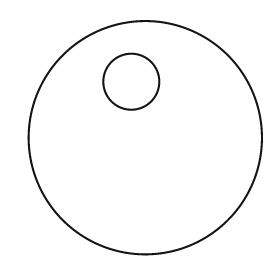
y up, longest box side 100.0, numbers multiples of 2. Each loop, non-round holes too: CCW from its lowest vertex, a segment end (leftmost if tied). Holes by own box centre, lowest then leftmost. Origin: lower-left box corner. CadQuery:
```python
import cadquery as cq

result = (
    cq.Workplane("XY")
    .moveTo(50.0, 50.0)
    .circle(50.0)
    .moveTo(44.0, 74.0)
    .circle(12.0)
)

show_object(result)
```